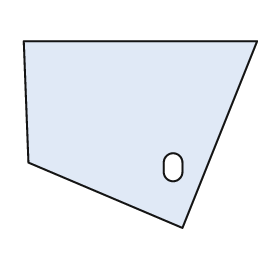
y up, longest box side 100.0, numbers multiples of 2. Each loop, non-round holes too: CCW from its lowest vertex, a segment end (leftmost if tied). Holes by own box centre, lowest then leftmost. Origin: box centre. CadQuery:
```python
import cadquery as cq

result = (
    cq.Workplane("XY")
    .moveTo(18.0, -40.0)
    .lineTo(50.0, 40.0)
    .lineTo(-50.0, 40.0)
    .lineTo(-48.0, -12.0)
    .close()
    .moveTo(10.0, -16.0)
    .threePointArc((14.0, -20.0), (18.0, -16.0))
    .lineTo(18.0, -12.0)
    .threePointArc((14.0, -8.0), (10.0, -12.0))
    .close()
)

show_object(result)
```